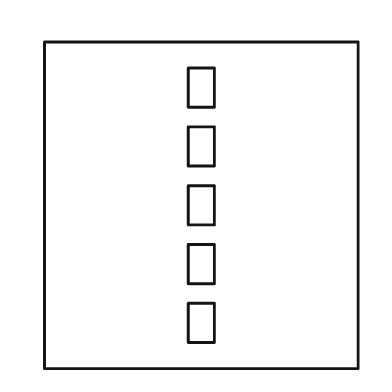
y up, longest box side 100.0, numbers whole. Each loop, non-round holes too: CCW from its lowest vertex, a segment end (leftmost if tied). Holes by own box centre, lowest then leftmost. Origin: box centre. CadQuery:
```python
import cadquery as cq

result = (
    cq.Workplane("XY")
    .moveTo(-48.0, -50.0)
    .lineTo(48.0, -50.0)
    .lineTo(48.0, 50.0)
    .lineTo(-48.0, 50.0)
    .close()
    .moveTo(-4.0, -42.0)
    .lineTo(4.0, -42.0)
    .lineTo(4.0, -30.0)
    .lineTo(-4.0, -30.0)
    .close()
    .moveTo(-4.0, -24.0)
    .lineTo(4.0, -24.0)
    .lineTo(4.0, -12.0)
    .lineTo(-4.0, -12.0)
    .close()
    .moveTo(-4.0, -6.0)
    .lineTo(4.0, -6.0)
    .lineTo(4.0, 6.0)
    .lineTo(-4.0, 6.0)
    .close()
    .moveTo(-4.0, 12.0)
    .lineTo(4.0, 12.0)
    .lineTo(4.0, 24.0)
    .lineTo(-4.0, 24.0)
    .close()
    .moveTo(-4.0, 30.0)
    .lineTo(4.0, 30.0)
    .lineTo(4.0, 42.0)
    .lineTo(-4.0, 42.0)
    .close()
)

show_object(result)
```